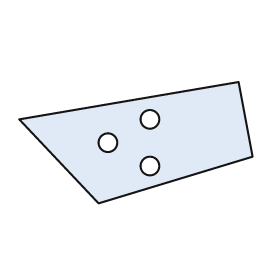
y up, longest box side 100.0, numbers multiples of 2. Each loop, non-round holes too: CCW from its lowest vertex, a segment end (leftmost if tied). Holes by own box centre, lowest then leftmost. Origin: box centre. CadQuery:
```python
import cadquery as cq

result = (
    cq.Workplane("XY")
    .moveTo(-16.0, -26.0)
    .lineTo(50.0, -6.0)
    .lineTo(44.0, 26.0)
    .lineTo(-50.0, 10.0)
    .close()
    .moveTo(6.0, -10.0)
    .circle(4.0)
    .moveTo(-12.0, 0.0)
    .circle(4.0)
    .moveTo(6.0, 10.0)
    .circle(4.0)
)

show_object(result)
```